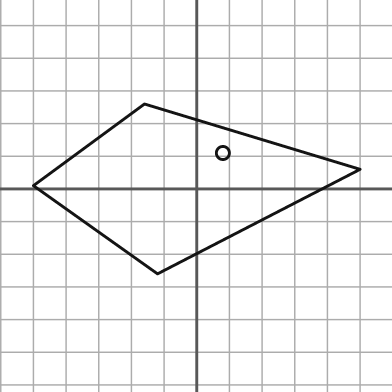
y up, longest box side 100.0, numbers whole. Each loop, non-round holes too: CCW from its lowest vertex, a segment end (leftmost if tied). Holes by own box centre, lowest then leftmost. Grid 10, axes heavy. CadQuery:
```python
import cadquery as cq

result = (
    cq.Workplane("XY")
    .moveTo(-12.0, -26.0)
    .lineTo(50.0, 6.0)
    .lineTo(-16.0, 26.0)
    .lineTo(-50.0, 1.0)
    .close()
    .moveTo(8.0, 11.0)
    .circle(2.0)
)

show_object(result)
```